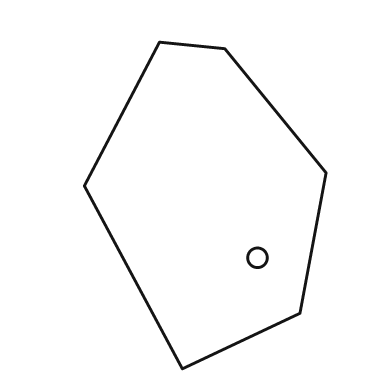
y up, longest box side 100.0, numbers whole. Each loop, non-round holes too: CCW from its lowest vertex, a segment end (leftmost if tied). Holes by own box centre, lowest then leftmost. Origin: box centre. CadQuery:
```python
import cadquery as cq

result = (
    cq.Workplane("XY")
    .moveTo(-7.0, -50.0)
    .lineTo(29.0, -33.0)
    .lineTo(37.0, 10.0)
    .lineTo(6.0, 48.0)
    .lineTo(-14.0, 50.0)
    .lineTo(-37.0, 6.0)
    .close()
    .moveTo(16.0, -16.0)
    .circle(3.0)
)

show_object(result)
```